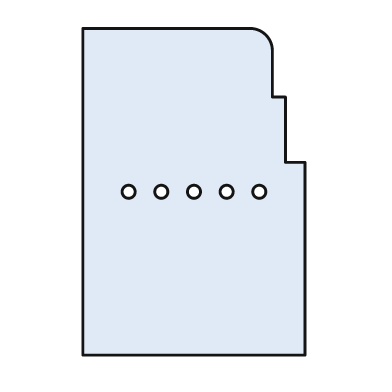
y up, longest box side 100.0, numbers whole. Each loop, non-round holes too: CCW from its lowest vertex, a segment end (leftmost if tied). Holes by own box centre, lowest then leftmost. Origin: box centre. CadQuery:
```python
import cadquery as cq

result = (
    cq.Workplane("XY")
    .moveTo(-34.0, -50.0)
    .lineTo(34.0, -50.0)
    .lineTo(34.0, 9.0)
    .lineTo(28.0, 9.0)
    .lineTo(28.0, 29.0)
    .lineTo(24.0, 29.0)
    .lineTo(24.0, 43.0)
    .threePointArc((22.0, 48.0), (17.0, 50.0))
    .lineTo(-34.0, 50.0)
    .close()
    .moveTo(-20.0, 0.0)
    .circle(2.0)
    .moveTo(-10.0, 0.0)
    .circle(2.0)
    .moveTo(0.0, 0.0)
    .circle(2.0)
    .moveTo(10.0, 0.0)
    .circle(2.0)
    .moveTo(20.0, 0.0)
    .circle(2.0)
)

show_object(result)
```